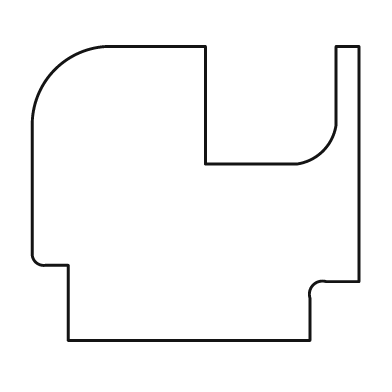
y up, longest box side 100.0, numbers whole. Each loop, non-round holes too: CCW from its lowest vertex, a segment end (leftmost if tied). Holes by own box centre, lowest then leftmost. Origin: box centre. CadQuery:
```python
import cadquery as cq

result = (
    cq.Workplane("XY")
    .moveTo(-39.0, -45.0)
    .lineTo(35.0, -45.0)
    .lineTo(35.0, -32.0)
    .threePointArc((36.0, -28.0), (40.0, -27.0))
    .lineTo(50.0, -27.0)
    .lineTo(50.0, 45.0)
    .lineTo(43.0, 45.0)
    .lineTo(43.0, 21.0)
    .threePointArc((39.0, 13.0), (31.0, 9.0))
    .lineTo(3.0, 9.0)
    .lineTo(3.0, 45.0)
    .lineTo(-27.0, 45.0)
    .threePointArc((-43.0, 38.0), (-50.0, 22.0))
    .lineTo(-50.0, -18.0)
    .threePointArc((-49.0, -21.0), (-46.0, -22.0))
    .lineTo(-39.0, -22.0)
    .close()
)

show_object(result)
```